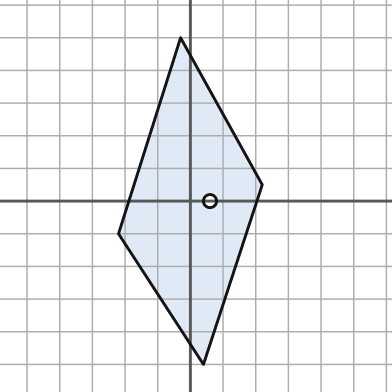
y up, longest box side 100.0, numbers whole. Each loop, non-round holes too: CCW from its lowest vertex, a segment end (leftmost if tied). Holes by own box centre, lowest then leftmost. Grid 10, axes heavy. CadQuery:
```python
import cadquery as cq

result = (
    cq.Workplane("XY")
    .moveTo(4.0, -50.0)
    .lineTo(22.0, 5.0)
    .lineTo(-3.0, 50.0)
    .lineTo(-22.0, -10.0)
    .close()
    .moveTo(6.0, 0.0)
    .circle(2.0)
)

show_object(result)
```